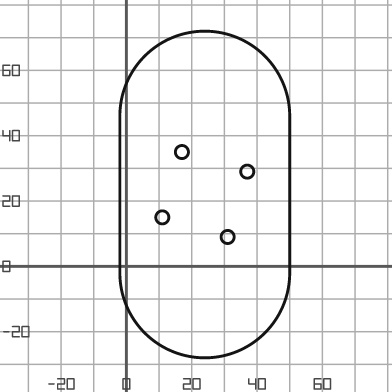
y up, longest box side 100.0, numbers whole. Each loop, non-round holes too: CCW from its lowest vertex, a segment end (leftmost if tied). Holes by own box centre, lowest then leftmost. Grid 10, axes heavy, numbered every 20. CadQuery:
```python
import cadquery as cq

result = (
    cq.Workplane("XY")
    .moveTo(-2.0, -2.0)
    .threePointArc((24.0, -28.0), (50.0, -2.0))
    .lineTo(50.0, 46.0)
    .threePointArc((24.0, 72.0), (-2.0, 46.0))
    .close()
    .moveTo(31.0, 9.0)
    .circle(2.0)
    .moveTo(11.0, 15.0)
    .circle(2.0)
    .moveTo(37.0, 29.0)
    .circle(2.0)
    .moveTo(17.0, 35.0)
    .circle(2.0)
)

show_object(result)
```